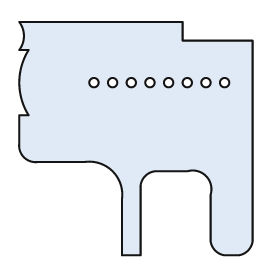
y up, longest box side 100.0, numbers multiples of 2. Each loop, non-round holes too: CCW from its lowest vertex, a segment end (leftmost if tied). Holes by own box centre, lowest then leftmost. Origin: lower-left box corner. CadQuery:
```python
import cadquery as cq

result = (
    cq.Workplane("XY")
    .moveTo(44.0, 0.0)
    .lineTo(52.0, 0.0)
    .lineTo(52.0, 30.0)
    .threePointArc((54.0, 34.0), (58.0, 36.0))
    .lineTo(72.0, 36.0)
    .threePointArc((80.0, 34.0), (82.0, 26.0))
    .lineTo(82.0, 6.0)
    .threePointArc((84.0, 2.0), (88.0, 0.0))
    .lineTo(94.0, 0.0)
    .threePointArc((98.0, 2.0), (100.0, 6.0))
    .lineTo(100.0, 92.0)
    .lineTo(70.0, 92.0)
    .lineTo(70.0, 100.0)
    .lineTo(0.0, 100.0)
    .threePointArc((2.0, 94.0), (0.0, 88.0))
    .lineTo(4.0, 88.0)
    .threePointArc((0.0, 74.0), (4.0, 60.0))
    .lineTo(0.0, 60.0)
    .lineTo(0.0, 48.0)
    .threePointArc((2.0, 42.0), (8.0, 40.0))
    .lineTo(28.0, 40.0)
    .threePointArc((40.0, 36.0), (44.0, 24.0))
    .close()
    .moveTo(32.0, 74.0)
    .circle(2.0)
    .moveTo(40.0, 74.0)
    .circle(2.0)
    .moveTo(48.0, 74.0)
    .circle(2.0)
    .moveTo(56.0, 74.0)
    .circle(2.0)
    .moveTo(64.0, 74.0)
    .circle(2.0)
    .moveTo(72.0, 74.0)
    .circle(2.0)
    .moveTo(80.0, 74.0)
    .circle(2.0)
    .moveTo(88.0, 74.0)
    .circle(2.0)
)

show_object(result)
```